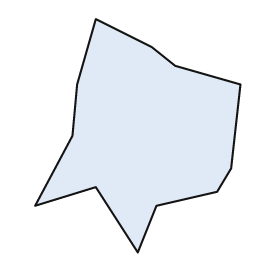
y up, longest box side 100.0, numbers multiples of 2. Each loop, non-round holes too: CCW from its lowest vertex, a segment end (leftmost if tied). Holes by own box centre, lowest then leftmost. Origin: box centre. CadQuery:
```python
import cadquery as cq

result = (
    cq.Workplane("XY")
    .moveTo(0.0, -50.0)
    .lineTo(8.0, -30.0)
    .lineTo(34.0, -24.0)
    .lineTo(40.0, -14.0)
    .lineTo(44.0, 22.0)
    .lineTo(16.0, 30.0)
    .lineTo(6.0, 38.0)
    .lineTo(-18.0, 50.0)
    .lineTo(-26.0, 22.0)
    .lineTo(-28.0, 0.0)
    .lineTo(-44.0, -30.0)
    .lineTo(-18.0, -22.0)
    .close()
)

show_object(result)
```